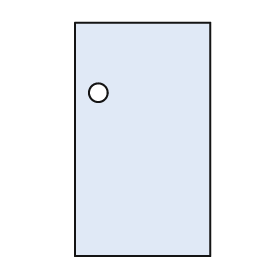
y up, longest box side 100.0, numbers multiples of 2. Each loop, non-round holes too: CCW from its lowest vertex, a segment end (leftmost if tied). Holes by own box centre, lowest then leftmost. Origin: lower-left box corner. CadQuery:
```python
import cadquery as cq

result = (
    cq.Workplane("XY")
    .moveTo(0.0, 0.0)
    .lineTo(58.0, 0.0)
    .lineTo(58.0, 100.0)
    .lineTo(0.0, 100.0)
    .close()
    .moveTo(10.0, 70.0)
    .circle(4.0)
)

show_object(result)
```